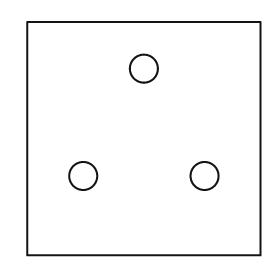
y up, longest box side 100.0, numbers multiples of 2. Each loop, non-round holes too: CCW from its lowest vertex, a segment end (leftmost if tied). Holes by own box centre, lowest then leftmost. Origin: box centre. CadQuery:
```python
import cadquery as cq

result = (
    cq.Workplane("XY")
    .moveTo(-50.0, -50.0)
    .lineTo(50.0, -50.0)
    .lineTo(50.0, 50.0)
    .lineTo(-50.0, 50.0)
    .close()
    .moveTo(-26.0, -16.0)
    .circle(6.0)
    .moveTo(26.0, -16.0)
    .circle(6.0)
    .moveTo(0.0, 30.0)
    .circle(6.0)
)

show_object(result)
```